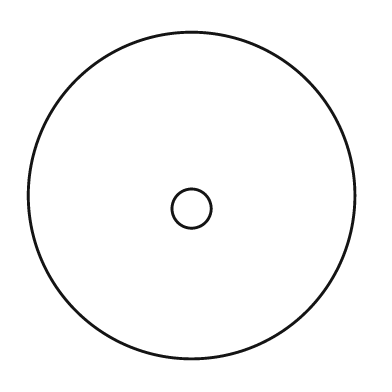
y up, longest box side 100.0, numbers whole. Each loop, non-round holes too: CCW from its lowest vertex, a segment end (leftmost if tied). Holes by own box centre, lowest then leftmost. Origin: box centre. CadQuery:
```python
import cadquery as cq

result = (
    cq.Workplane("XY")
    .moveTo(0.0, 0.0)
    .circle(50.0)
    .moveTo(0.0, -4.0)
    .circle(6.0)
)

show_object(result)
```